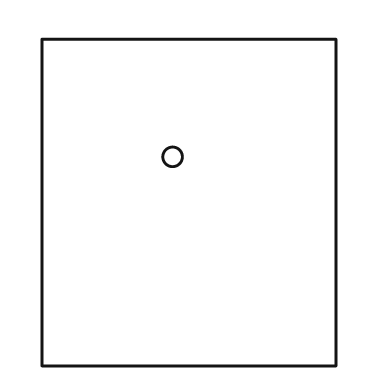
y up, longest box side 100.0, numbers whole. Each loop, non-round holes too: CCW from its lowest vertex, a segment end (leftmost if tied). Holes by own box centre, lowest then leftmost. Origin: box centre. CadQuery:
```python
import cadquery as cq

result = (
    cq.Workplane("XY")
    .moveTo(-45.0, -50.0)
    .lineTo(45.0, -50.0)
    .lineTo(45.0, 50.0)
    .lineTo(-45.0, 50.0)
    .close()
    .moveTo(-5.0, 14.0)
    .circle(3.0)
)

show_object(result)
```